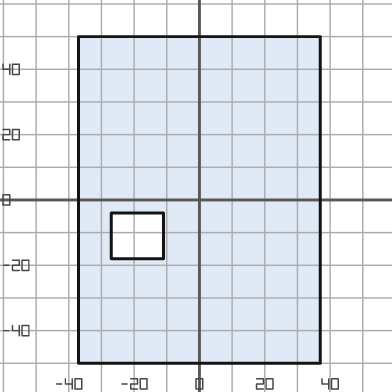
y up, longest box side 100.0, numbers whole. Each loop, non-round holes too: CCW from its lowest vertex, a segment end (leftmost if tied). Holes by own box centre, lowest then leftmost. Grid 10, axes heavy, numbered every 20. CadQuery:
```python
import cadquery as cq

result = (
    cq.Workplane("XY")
    .moveTo(-37.0, -50.0)
    .lineTo(37.0, -50.0)
    .lineTo(37.0, 50.0)
    .lineTo(-37.0, 50.0)
    .close()
    .moveTo(-27.0, -18.0)
    .lineTo(-11.0, -18.0)
    .lineTo(-11.0, -4.0)
    .lineTo(-27.0, -4.0)
    .close()
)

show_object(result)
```